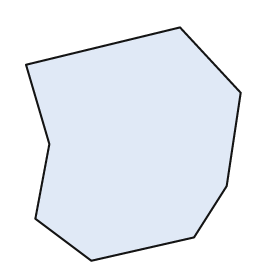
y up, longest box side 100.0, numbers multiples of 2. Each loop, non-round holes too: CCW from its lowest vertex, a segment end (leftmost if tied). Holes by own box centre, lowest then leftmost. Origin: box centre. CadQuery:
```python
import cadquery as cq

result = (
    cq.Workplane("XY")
    .moveTo(-18.0, -50.0)
    .lineTo(26.0, -40.0)
    .lineTo(40.0, -18.0)
    .lineTo(46.0, 22.0)
    .lineTo(20.0, 50.0)
    .lineTo(-46.0, 34.0)
    .lineTo(-36.0, 0.0)
    .lineTo(-42.0, -32.0)
    .close()
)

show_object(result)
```